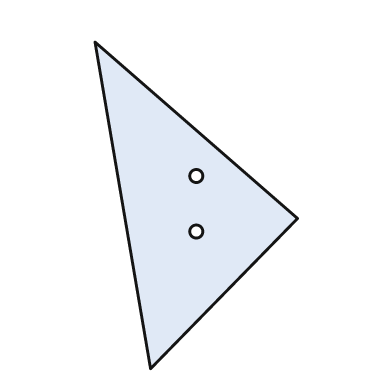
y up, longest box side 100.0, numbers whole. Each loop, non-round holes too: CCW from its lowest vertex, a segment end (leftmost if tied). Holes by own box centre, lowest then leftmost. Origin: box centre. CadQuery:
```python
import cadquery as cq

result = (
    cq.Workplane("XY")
    .moveTo(-14.0, -50.0)
    .lineTo(31.0, -4.0)
    .lineTo(-31.0, 50.0)
    .close()
    .moveTo(0.0, -8.0)
    .circle(2.0)
    .moveTo(0.0, 9.0)
    .circle(2.0)
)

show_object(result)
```